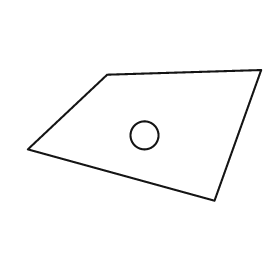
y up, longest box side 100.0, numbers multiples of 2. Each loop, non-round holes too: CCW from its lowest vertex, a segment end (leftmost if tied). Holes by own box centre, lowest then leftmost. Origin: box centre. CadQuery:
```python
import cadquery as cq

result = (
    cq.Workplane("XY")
    .moveTo(30.0, -28.0)
    .lineTo(50.0, 28.0)
    .lineTo(-16.0, 26.0)
    .lineTo(-50.0, -6.0)
    .close()
    .moveTo(0.0, 0.0)
    .circle(6.0)
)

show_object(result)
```